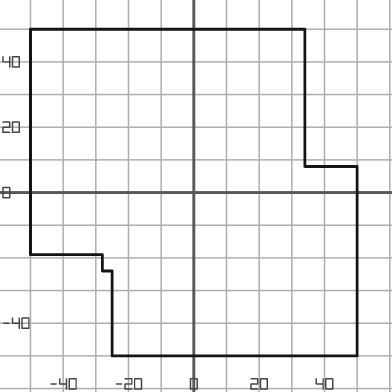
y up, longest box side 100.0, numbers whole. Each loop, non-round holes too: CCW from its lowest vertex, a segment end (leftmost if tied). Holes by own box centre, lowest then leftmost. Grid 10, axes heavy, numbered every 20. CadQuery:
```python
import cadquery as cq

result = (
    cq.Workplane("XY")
    .moveTo(-25.0, -50.0)
    .lineTo(50.0, -50.0)
    .lineTo(50.0, 8.0)
    .lineTo(34.0, 8.0)
    .lineTo(34.0, 50.0)
    .lineTo(-50.0, 50.0)
    .lineTo(-50.0, -19.0)
    .lineTo(-28.0, -19.0)
    .lineTo(-28.0, -24.0)
    .lineTo(-25.0, -24.0)
    .close()
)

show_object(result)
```